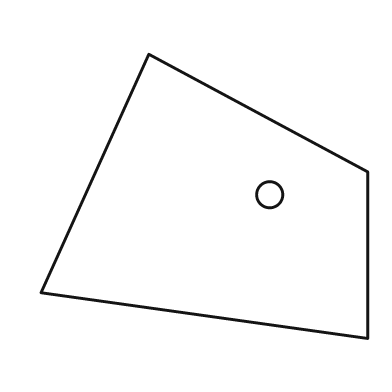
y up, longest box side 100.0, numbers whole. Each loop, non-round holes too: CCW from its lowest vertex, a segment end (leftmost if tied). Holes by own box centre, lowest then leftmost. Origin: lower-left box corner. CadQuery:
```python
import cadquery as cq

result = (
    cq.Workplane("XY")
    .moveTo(100.0, 0.0)
    .lineTo(100.0, 51.0)
    .lineTo(33.0, 87.0)
    .lineTo(0.0, 14.0)
    .close()
    .moveTo(70.0, 44.0)
    .circle(4.0)
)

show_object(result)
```